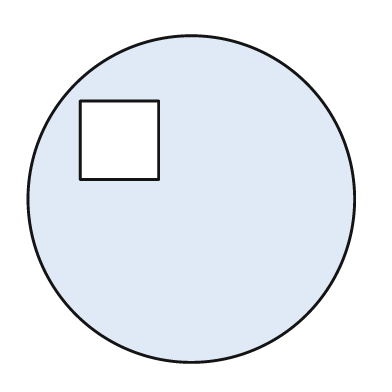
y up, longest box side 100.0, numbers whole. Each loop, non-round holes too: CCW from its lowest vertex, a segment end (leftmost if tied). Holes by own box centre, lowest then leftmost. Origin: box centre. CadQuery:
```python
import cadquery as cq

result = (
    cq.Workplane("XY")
    .moveTo(0.0, 0.0)
    .circle(50.0)
    .moveTo(-34.0, 6.0)
    .lineTo(-10.0, 6.0)
    .lineTo(-10.0, 30.0)
    .lineTo(-34.0, 30.0)
    .close()
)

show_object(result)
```